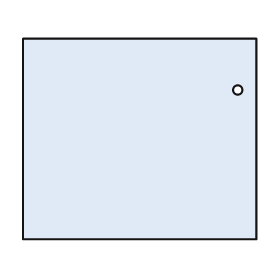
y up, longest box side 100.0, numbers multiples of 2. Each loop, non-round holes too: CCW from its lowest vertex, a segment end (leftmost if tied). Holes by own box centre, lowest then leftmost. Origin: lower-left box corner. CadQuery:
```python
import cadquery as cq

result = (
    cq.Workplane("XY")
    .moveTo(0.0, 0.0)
    .lineTo(100.0, 0.0)
    .lineTo(100.0, 86.0)
    .lineTo(0.0, 86.0)
    .close()
    .moveTo(92.0, 64.0)
    .circle(2.0)
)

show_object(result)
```